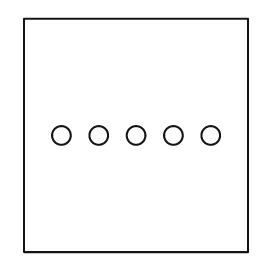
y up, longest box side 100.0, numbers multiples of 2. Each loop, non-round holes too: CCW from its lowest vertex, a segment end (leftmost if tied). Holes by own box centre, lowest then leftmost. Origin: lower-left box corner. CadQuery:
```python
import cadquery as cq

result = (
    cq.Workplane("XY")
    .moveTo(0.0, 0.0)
    .lineTo(96.0, 0.0)
    .lineTo(96.0, 100.0)
    .lineTo(0.0, 100.0)
    .close()
    .moveTo(16.0, 50.0)
    .circle(4.0)
    .moveTo(32.0, 50.0)
    .circle(4.0)
    .moveTo(48.0, 50.0)
    .circle(4.0)
    .moveTo(64.0, 50.0)
    .circle(4.0)
    .moveTo(80.0, 50.0)
    .circle(4.0)
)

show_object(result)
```